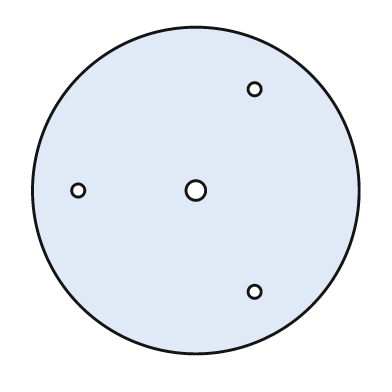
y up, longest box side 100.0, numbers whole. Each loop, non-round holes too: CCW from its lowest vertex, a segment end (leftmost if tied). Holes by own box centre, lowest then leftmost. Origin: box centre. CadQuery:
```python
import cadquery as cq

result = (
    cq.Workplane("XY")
    .moveTo(0.0, 0.0)
    .circle(50.0)
    .moveTo(18.0, -31.0)
    .circle(2.0)
    .moveTo(-36.0, 0.0)
    .circle(2.0)
    .moveTo(0.0, 0.0)
    .circle(3.0)
    .moveTo(18.0, 31.0)
    .circle(2.0)
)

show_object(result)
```